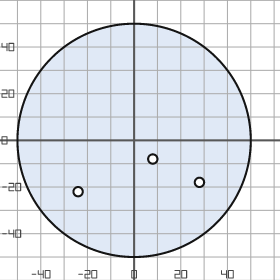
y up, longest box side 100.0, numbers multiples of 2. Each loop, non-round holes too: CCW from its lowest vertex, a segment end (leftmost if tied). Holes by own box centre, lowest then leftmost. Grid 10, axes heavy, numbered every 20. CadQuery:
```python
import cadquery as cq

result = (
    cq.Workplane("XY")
    .moveTo(0.0, 0.0)
    .circle(50.0)
    .moveTo(-24.0, -22.0)
    .circle(2.0)
    .moveTo(28.0, -18.0)
    .circle(2.0)
    .moveTo(8.0, -8.0)
    .circle(2.0)
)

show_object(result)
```